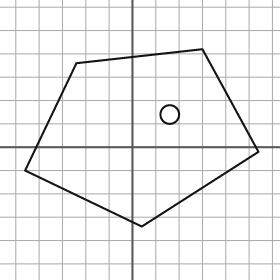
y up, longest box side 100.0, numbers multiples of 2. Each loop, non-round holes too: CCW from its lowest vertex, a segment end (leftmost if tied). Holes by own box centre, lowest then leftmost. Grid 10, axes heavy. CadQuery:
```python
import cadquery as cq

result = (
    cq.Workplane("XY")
    .moveTo(4.0, -34.0)
    .lineTo(54.0, -2.0)
    .lineTo(30.0, 42.0)
    .lineTo(-24.0, 36.0)
    .lineTo(-46.0, -10.0)
    .close()
    .moveTo(16.0, 14.0)
    .circle(4.0)
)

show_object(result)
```